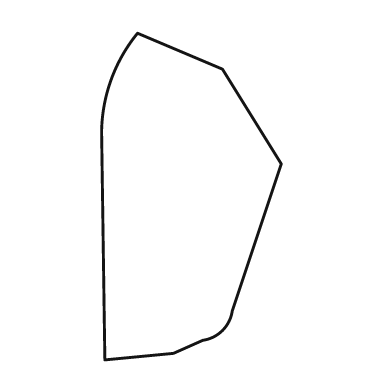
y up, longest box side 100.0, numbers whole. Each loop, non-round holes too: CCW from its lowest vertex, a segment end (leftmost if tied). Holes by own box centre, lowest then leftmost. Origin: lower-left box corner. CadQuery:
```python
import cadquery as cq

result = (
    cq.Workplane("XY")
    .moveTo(1.0, 0.0)
    .lineTo(22.0, 2.0)
    .lineTo(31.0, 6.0)
    .threePointArc((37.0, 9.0), (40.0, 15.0))
    .lineTo(55.0, 60.0)
    .lineTo(37.0, 89.0)
    .lineTo(11.0, 100.0)
    .threePointArc((3.0, 86.0), (0.0, 70.0))
    .close()
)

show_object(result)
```